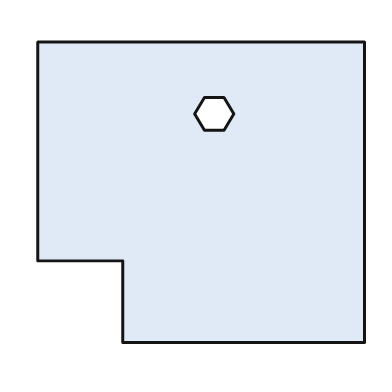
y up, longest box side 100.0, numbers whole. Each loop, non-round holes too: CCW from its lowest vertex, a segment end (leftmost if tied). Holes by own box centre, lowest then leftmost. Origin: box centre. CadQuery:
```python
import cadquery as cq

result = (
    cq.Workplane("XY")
    .moveTo(-24.0, -46.0)
    .lineTo(50.0, -46.0)
    .lineTo(50.0, 46.0)
    .lineTo(-50.0, 46.0)
    .lineTo(-50.0, -21.0)
    .lineTo(-24.0, -21.0)
    .close()
    .moveTo(1.0, 19.0)
    .lineTo(7.0, 19.0)
    .lineTo(10.0, 24.0)
    .lineTo(7.0, 29.0)
    .lineTo(1.0, 29.0)
    .lineTo(-2.0, 24.0)
    .close()
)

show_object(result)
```